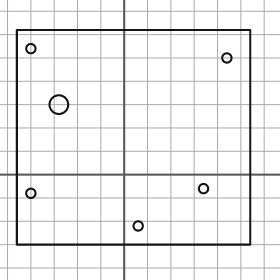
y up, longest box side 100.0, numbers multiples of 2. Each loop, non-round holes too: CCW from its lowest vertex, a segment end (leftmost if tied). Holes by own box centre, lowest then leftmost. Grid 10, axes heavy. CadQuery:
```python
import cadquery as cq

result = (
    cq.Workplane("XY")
    .moveTo(-46.0, -30.0)
    .lineTo(54.0, -30.0)
    .lineTo(54.0, 62.0)
    .lineTo(-46.0, 62.0)
    .close()
    .moveTo(6.0, -22.0)
    .circle(2.0)
    .moveTo(-40.0, -8.0)
    .circle(2.0)
    .moveTo(34.0, -6.0)
    .circle(2.0)
    .moveTo(-28.0, 30.0)
    .circle(4.0)
    .moveTo(44.0, 50.0)
    .circle(2.0)
    .moveTo(-40.0, 54.0)
    .circle(2.0)
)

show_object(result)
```